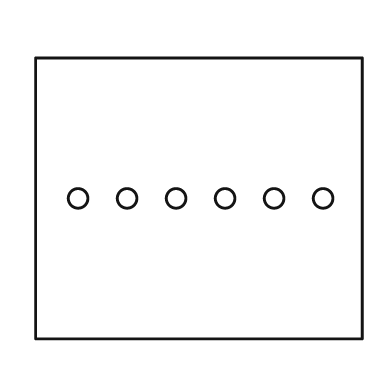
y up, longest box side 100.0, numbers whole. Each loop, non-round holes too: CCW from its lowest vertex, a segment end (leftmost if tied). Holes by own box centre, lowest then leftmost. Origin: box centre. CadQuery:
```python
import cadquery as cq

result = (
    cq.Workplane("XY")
    .moveTo(-50.0, -43.0)
    .lineTo(50.0, -43.0)
    .lineTo(50.0, 43.0)
    .lineTo(-50.0, 43.0)
    .close()
    .moveTo(-37.0, 0.0)
    .circle(3.0)
    .moveTo(-22.0, 0.0)
    .circle(3.0)
    .moveTo(-7.0, 0.0)
    .circle(3.0)
    .moveTo(8.0, 0.0)
    .circle(3.0)
    .moveTo(23.0, 0.0)
    .circle(3.0)
    .moveTo(38.0, 0.0)
    .circle(3.0)
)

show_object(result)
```